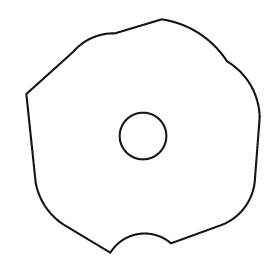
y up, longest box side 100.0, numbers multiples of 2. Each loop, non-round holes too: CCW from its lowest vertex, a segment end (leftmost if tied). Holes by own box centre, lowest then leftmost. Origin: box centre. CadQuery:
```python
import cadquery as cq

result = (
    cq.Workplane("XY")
    .moveTo(-14.0, -50.0)
    .threePointArc((-2.0, -42.0), (12.0, -46.0))
    .lineTo(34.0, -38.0)
    .threePointArc((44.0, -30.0), (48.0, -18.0))
    .lineTo(50.0, 8.0)
    .threePointArc((46.0, 22.0), (36.0, 32.0))
    .threePointArc((24.0, 44.0), (8.0, 50.0))
    .lineTo(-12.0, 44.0)
    .threePointArc((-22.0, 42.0), (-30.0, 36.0))
    .lineTo(-50.0, 18.0)
    .lineTo(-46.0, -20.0)
    .threePointArc((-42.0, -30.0), (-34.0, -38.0))
    .close()
    .moveTo(0.0, 0.0)
    .circle(10.0)
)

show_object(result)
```